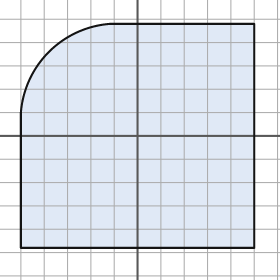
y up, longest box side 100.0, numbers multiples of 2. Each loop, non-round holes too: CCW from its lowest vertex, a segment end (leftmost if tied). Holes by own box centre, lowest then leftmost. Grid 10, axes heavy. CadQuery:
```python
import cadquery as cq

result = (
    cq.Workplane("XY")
    .moveTo(-50.0, -48.0)
    .lineTo(50.0, -48.0)
    .lineTo(50.0, 48.0)
    .lineTo(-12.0, 48.0)
    .threePointArc((-38.0, 36.0), (-50.0, 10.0))
    .close()
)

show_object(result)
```